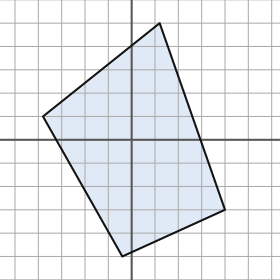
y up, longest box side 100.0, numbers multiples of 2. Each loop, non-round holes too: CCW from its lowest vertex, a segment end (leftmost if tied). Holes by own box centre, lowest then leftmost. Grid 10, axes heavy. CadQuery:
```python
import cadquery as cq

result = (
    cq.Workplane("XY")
    .moveTo(-4.0, -50.0)
    .lineTo(40.0, -30.0)
    .lineTo(12.0, 50.0)
    .lineTo(-38.0, 10.0)
    .close()
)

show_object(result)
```